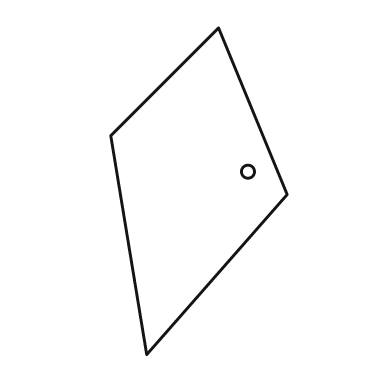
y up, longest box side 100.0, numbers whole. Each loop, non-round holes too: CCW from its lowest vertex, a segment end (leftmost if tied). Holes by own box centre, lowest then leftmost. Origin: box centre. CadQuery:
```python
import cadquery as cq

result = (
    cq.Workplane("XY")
    .moveTo(-16.0, -50.0)
    .lineTo(27.0, -1.0)
    .lineTo(6.0, 50.0)
    .lineTo(-27.0, 17.0)
    .close()
    .moveTo(15.0, 6.0)
    .circle(2.0)
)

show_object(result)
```